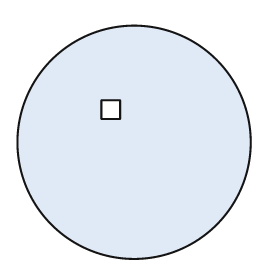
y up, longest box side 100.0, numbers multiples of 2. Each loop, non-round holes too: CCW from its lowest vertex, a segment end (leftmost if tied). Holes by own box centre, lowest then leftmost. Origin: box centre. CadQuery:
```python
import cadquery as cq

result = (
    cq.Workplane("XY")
    .moveTo(0.0, 0.0)
    .circle(50.0)
    .moveTo(-14.0, 10.0)
    .lineTo(-6.0, 10.0)
    .lineTo(-6.0, 18.0)
    .lineTo(-14.0, 18.0)
    .close()
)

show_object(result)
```